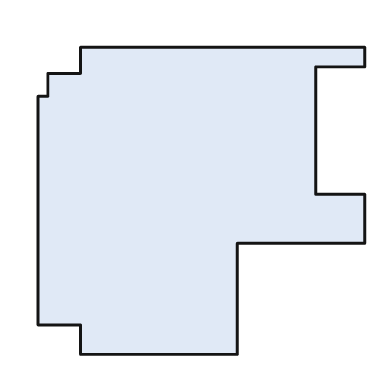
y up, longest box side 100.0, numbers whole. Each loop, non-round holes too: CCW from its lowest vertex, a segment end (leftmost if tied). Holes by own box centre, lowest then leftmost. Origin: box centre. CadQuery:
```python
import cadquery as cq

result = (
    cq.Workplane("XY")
    .moveTo(-37.0, -47.0)
    .lineTo(11.0, -47.0)
    .lineTo(11.0, -13.0)
    .lineTo(50.0, -13.0)
    .lineTo(50.0, 2.0)
    .lineTo(35.0, 2.0)
    .lineTo(35.0, 41.0)
    .lineTo(50.0, 41.0)
    .lineTo(50.0, 47.0)
    .lineTo(-37.0, 47.0)
    .lineTo(-37.0, 39.0)
    .lineTo(-47.0, 39.0)
    .lineTo(-47.0, 32.0)
    .lineTo(-50.0, 32.0)
    .lineTo(-50.0, -38.0)
    .lineTo(-37.0, -38.0)
    .close()
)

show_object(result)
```